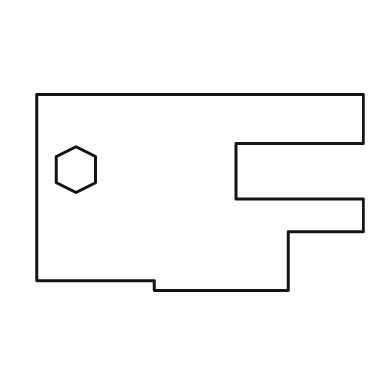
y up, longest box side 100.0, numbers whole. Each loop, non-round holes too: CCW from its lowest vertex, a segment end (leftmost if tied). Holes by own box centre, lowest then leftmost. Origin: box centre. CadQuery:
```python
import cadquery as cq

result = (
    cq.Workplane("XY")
    .moveTo(-14.0, -30.0)
    .lineTo(27.0, -30.0)
    .lineTo(27.0, -12.0)
    .lineTo(50.0, -12.0)
    .lineTo(50.0, -2.0)
    .lineTo(11.0, -2.0)
    .lineTo(11.0, 15.0)
    .lineTo(50.0, 15.0)
    .lineTo(50.0, 30.0)
    .lineTo(-50.0, 30.0)
    .lineTo(-50.0, -27.0)
    .lineTo(-14.0, -27.0)
    .close()
    .moveTo(-38.0, 0.0)
    .lineTo(-32.0, 3.0)
    .lineTo(-32.0, 11.0)
    .lineTo(-38.0, 14.0)
    .lineTo(-44.0, 11.0)
    .lineTo(-44.0, 3.0)
    .close()
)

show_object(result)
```